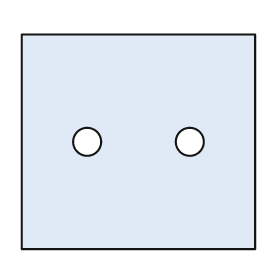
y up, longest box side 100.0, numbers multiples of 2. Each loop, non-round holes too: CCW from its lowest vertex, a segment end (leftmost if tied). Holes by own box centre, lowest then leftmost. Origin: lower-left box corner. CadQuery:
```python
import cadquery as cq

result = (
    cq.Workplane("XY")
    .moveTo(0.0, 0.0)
    .lineTo(100.0, 0.0)
    .lineTo(100.0, 92.0)
    .lineTo(0.0, 92.0)
    .close()
    .moveTo(28.0, 46.0)
    .circle(6.0)
    .moveTo(72.0, 46.0)
    .circle(6.0)
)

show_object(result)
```